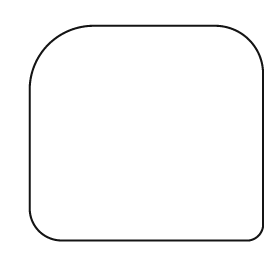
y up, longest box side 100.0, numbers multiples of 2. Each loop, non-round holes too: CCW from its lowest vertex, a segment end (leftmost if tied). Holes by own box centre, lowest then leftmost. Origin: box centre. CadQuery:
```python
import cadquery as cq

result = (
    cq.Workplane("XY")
    .moveTo(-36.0, -46.0)
    .lineTo(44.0, -46.0)
    .threePointArc((48.0, -44.0), (50.0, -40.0))
    .lineTo(50.0, 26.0)
    .threePointArc((44.0, 40.0), (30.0, 46.0))
    .lineTo(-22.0, 46.0)
    .threePointArc((-42.0, 38.0), (-50.0, 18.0))
    .lineTo(-50.0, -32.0)
    .threePointArc((-46.0, -42.0), (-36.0, -46.0))
    .close()
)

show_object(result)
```